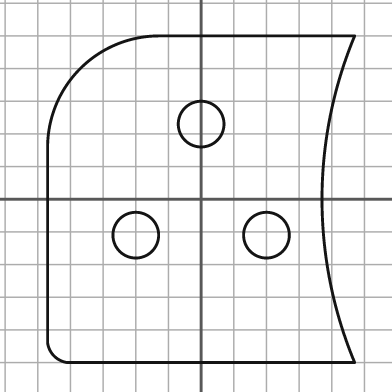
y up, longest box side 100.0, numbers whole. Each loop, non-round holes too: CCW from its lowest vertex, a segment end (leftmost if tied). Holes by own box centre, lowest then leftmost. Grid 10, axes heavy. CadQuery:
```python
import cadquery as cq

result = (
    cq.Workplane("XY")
    .moveTo(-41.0, -50.0)
    .lineTo(47.0, -50.0)
    .threePointArc((37.0, 0.0), (47.0, 50.0))
    .lineTo(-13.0, 50.0)
    .threePointArc((-37.0, 40.0), (-47.0, 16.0))
    .lineTo(-47.0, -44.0)
    .threePointArc((-45.0, -48.0), (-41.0, -50.0))
    .close()
    .moveTo(-20.0, -11.0)
    .circle(7.0)
    .moveTo(20.0, -11.0)
    .circle(7.0)
    .moveTo(0.0, 23.0)
    .circle(7.0)
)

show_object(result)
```